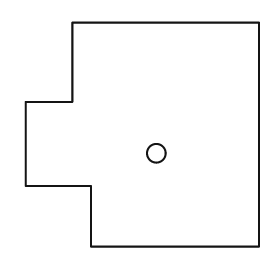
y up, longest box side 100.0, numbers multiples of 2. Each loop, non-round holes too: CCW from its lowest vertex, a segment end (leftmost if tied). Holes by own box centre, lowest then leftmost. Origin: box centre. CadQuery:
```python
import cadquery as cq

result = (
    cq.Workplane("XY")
    .moveTo(-22.0, -48.0)
    .lineTo(50.0, -48.0)
    .lineTo(50.0, 48.0)
    .lineTo(-30.0, 48.0)
    .lineTo(-30.0, 14.0)
    .lineTo(-50.0, 14.0)
    .lineTo(-50.0, -22.0)
    .lineTo(-22.0, -22.0)
    .close()
    .moveTo(6.0, -8.0)
    .circle(4.0)
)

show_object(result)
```